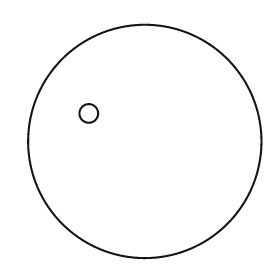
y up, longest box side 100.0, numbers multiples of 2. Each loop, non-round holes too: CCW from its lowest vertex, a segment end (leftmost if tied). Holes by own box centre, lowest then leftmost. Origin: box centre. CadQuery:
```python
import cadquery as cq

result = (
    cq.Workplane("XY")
    .moveTo(0.0, 0.0)
    .circle(50.0)
    .moveTo(-24.0, 12.0)
    .circle(4.0)
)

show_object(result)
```